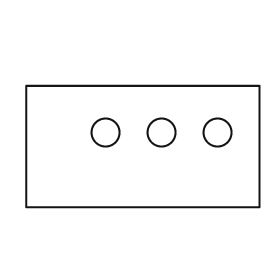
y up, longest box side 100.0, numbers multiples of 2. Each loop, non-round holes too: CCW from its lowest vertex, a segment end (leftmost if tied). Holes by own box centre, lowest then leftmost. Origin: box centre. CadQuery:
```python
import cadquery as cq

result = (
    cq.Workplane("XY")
    .moveTo(-50.0, -26.0)
    .lineTo(50.0, -26.0)
    .lineTo(50.0, 26.0)
    .lineTo(-50.0, 26.0)
    .close()
    .moveTo(-16.0, 6.0)
    .circle(6.0)
    .moveTo(8.0, 6.0)
    .circle(6.0)
    .moveTo(32.0, 6.0)
    .circle(6.0)
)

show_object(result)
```